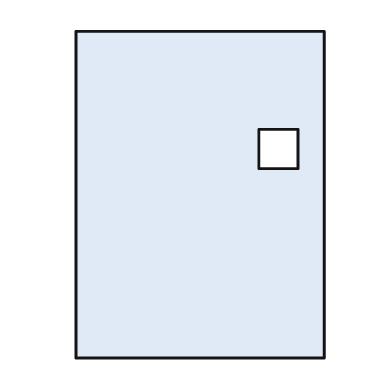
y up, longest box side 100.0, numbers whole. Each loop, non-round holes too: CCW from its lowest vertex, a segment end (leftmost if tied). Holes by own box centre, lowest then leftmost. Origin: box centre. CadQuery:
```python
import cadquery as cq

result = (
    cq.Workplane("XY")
    .moveTo(-38.0, -50.0)
    .lineTo(38.0, -50.0)
    .lineTo(38.0, 50.0)
    .lineTo(-38.0, 50.0)
    .close()
    .moveTo(18.0, 8.0)
    .lineTo(30.0, 8.0)
    .lineTo(30.0, 20.0)
    .lineTo(18.0, 20.0)
    .close()
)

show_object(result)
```